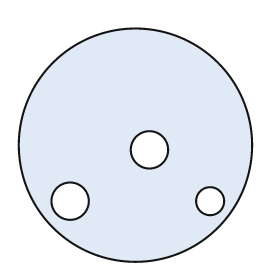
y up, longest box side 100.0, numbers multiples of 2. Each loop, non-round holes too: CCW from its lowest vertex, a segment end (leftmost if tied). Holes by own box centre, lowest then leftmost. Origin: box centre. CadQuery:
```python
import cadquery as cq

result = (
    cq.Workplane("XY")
    .moveTo(0.0, 0.0)
    .circle(50.0)
    .moveTo(-28.0, -24.0)
    .circle(8.0)
    .moveTo(32.0, -24.0)
    .circle(6.0)
    .moveTo(6.0, -2.0)
    .circle(8.0)
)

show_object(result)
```